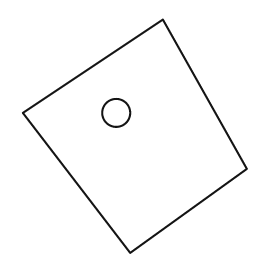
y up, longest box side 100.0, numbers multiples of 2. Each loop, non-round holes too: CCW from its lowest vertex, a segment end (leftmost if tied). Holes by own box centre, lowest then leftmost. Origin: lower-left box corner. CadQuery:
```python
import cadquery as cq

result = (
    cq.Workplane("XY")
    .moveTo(46.0, 0.0)
    .lineTo(96.0, 36.0)
    .lineTo(60.0, 100.0)
    .lineTo(0.0, 60.0)
    .close()
    .moveTo(40.0, 60.0)
    .circle(6.0)
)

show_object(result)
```